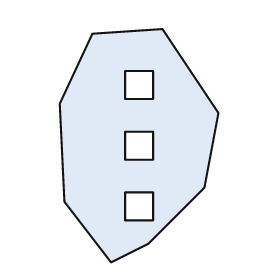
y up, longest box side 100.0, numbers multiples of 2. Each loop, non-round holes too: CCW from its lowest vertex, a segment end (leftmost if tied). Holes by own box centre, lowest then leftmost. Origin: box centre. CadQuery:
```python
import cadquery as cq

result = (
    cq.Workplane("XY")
    .moveTo(-12.0, -50.0)
    .lineTo(4.0, -42.0)
    .lineTo(28.0, -18.0)
    .lineTo(34.0, 14.0)
    .lineTo(10.0, 50.0)
    .lineTo(-20.0, 48.0)
    .lineTo(-34.0, 18.0)
    .lineTo(-32.0, -24.0)
    .close()
    .moveTo(-6.0, -32.0)
    .lineTo(6.0, -32.0)
    .lineTo(6.0, -20.0)
    .lineTo(-6.0, -20.0)
    .close()
    .moveTo(-6.0, -6.0)
    .lineTo(6.0, -6.0)
    .lineTo(6.0, 6.0)
    .lineTo(-6.0, 6.0)
    .close()
    .moveTo(-6.0, 20.0)
    .lineTo(6.0, 20.0)
    .lineTo(6.0, 32.0)
    .lineTo(-6.0, 32.0)
    .close()
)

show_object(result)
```